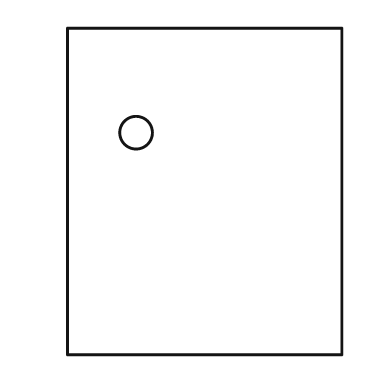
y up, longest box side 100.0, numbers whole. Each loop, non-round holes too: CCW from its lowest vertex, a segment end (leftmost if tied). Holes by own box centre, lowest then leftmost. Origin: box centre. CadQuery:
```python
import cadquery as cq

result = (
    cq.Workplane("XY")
    .moveTo(-42.0, -50.0)
    .lineTo(42.0, -50.0)
    .lineTo(42.0, 50.0)
    .lineTo(-42.0, 50.0)
    .close()
    .moveTo(-21.0, 18.0)
    .circle(5.0)
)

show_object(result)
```